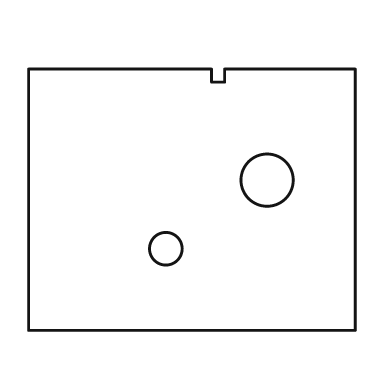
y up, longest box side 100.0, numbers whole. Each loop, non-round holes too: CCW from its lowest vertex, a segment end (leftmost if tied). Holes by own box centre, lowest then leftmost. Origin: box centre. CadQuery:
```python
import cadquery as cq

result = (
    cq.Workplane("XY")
    .moveTo(-50.0, -40.0)
    .lineTo(50.0, -40.0)
    .lineTo(50.0, 40.0)
    .lineTo(10.0, 40.0)
    .lineTo(10.0, 36.0)
    .lineTo(6.0, 36.0)
    .lineTo(6.0, 40.0)
    .lineTo(-50.0, 40.0)
    .close()
    .moveTo(-8.0, -15.0)
    .circle(5.0)
    .moveTo(23.0, 6.0)
    .circle(8.0)
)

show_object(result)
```